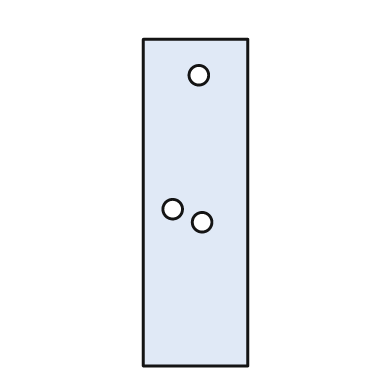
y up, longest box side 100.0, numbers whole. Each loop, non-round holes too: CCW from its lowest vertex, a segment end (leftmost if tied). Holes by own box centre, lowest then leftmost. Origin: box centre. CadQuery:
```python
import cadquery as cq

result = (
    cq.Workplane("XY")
    .moveTo(-16.0, -50.0)
    .lineTo(16.0, -50.0)
    .lineTo(16.0, 50.0)
    .lineTo(-16.0, 50.0)
    .close()
    .moveTo(2.0, -6.0)
    .circle(3.0)
    .moveTo(-7.0, -2.0)
    .circle(3.0)
    .moveTo(1.0, 39.0)
    .circle(3.0)
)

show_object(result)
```